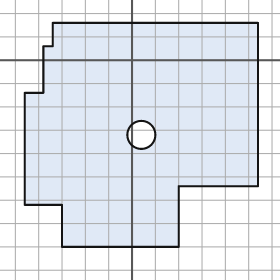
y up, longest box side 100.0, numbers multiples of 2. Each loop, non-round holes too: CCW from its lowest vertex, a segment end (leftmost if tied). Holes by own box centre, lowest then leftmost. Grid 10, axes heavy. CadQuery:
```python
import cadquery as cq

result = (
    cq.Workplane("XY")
    .moveTo(-30.0, -80.0)
    .lineTo(20.0, -80.0)
    .lineTo(20.0, -54.0)
    .lineTo(54.0, -54.0)
    .lineTo(54.0, 16.0)
    .lineTo(-34.0, 16.0)
    .lineTo(-34.0, 6.0)
    .lineTo(-38.0, 6.0)
    .lineTo(-38.0, -14.0)
    .lineTo(-46.0, -14.0)
    .lineTo(-46.0, -62.0)
    .lineTo(-30.0, -62.0)
    .close()
    .moveTo(4.0, -32.0)
    .circle(6.0)
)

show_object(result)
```